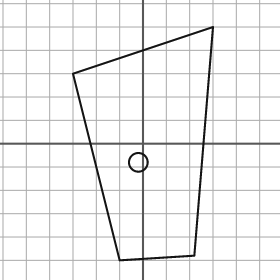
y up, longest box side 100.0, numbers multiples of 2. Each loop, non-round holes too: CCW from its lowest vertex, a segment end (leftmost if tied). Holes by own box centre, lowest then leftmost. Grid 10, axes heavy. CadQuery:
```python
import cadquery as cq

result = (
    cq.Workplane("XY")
    .moveTo(-10.0, -50.0)
    .lineTo(22.0, -48.0)
    .lineTo(30.0, 50.0)
    .lineTo(-30.0, 30.0)
    .close()
    .moveTo(-2.0, -8.0)
    .circle(4.0)
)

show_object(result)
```